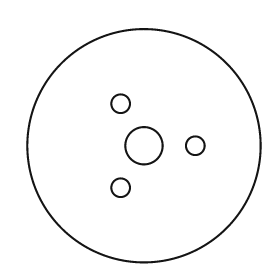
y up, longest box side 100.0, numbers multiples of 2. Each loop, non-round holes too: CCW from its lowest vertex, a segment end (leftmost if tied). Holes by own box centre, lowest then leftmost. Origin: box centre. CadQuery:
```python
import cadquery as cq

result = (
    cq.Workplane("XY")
    .moveTo(0.0, 0.0)
    .circle(50.0)
    .moveTo(-10.0, -18.0)
    .circle(4.0)
    .moveTo(0.0, 0.0)
    .circle(8.0)
    .moveTo(22.0, 0.0)
    .circle(4.0)
    .moveTo(-10.0, 18.0)
    .circle(4.0)
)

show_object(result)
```